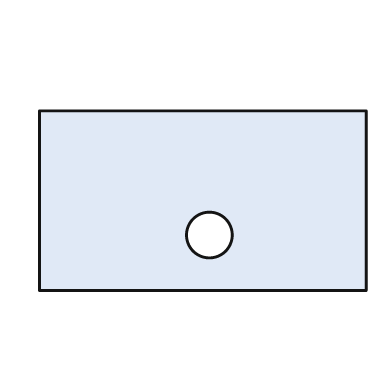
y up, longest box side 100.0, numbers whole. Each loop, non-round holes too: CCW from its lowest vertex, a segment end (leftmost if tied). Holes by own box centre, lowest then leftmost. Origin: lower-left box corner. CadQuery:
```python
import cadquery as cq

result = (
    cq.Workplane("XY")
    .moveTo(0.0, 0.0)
    .lineTo(100.0, 0.0)
    .lineTo(100.0, 55.0)
    .lineTo(0.0, 55.0)
    .close()
    .moveTo(52.0, 17.0)
    .circle(7.0)
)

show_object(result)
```